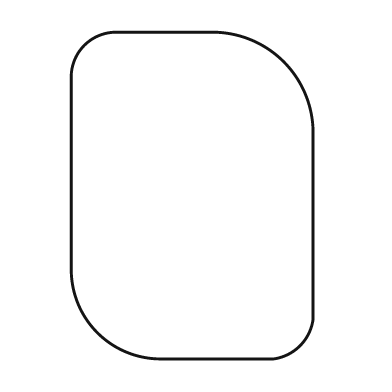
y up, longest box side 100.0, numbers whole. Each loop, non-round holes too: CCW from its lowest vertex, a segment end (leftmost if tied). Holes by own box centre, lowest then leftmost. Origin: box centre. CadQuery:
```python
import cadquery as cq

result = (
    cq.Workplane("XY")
    .moveTo(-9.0, -50.0)
    .lineTo(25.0, -50.0)
    .threePointArc((33.0, -46.0), (37.0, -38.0))
    .lineTo(37.0, 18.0)
    .threePointArc((28.0, 41.0), (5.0, 50.0))
    .lineTo(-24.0, 50.0)
    .threePointArc((-33.0, 46.0), (-37.0, 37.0))
    .lineTo(-37.0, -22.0)
    .threePointArc((-29.0, -42.0), (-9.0, -50.0))
    .close()
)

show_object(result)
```